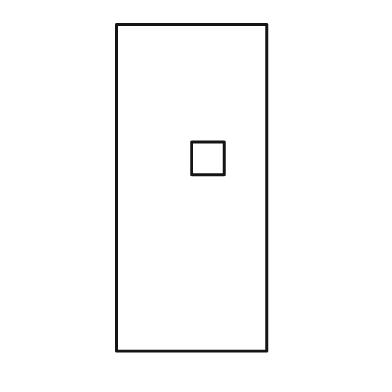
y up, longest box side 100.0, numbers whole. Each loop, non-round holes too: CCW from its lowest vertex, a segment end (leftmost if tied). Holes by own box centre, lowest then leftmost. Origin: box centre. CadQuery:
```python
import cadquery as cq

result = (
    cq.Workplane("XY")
    .moveTo(-23.0, -50.0)
    .lineTo(23.0, -50.0)
    .lineTo(23.0, 50.0)
    .lineTo(-23.0, 50.0)
    .close()
    .moveTo(0.0, 4.0)
    .lineTo(10.0, 4.0)
    .lineTo(10.0, 14.0)
    .lineTo(0.0, 14.0)
    .close()
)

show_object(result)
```